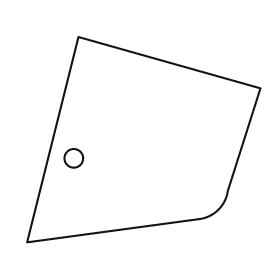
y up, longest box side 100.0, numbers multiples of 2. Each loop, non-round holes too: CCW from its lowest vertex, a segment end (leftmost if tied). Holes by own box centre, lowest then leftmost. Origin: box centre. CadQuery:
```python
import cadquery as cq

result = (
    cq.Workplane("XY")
    .moveTo(-50.0, -44.0)
    .lineTo(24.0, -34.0)
    .threePointArc((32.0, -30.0), (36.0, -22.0))
    .lineTo(50.0, 22.0)
    .lineTo(-28.0, 44.0)
    .close()
    .moveTo(-30.0, -8.0)
    .circle(4.0)
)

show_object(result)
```